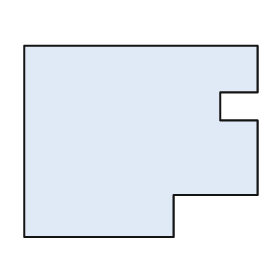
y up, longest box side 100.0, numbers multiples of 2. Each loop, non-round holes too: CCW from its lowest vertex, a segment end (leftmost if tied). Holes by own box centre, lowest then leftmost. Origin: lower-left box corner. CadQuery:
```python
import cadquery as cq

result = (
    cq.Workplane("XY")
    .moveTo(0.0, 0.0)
    .lineTo(64.0, 0.0)
    .lineTo(64.0, 18.0)
    .lineTo(100.0, 18.0)
    .lineTo(100.0, 50.0)
    .lineTo(84.0, 50.0)
    .lineTo(84.0, 62.0)
    .lineTo(100.0, 62.0)
    .lineTo(100.0, 82.0)
    .lineTo(0.0, 82.0)
    .close()
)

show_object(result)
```